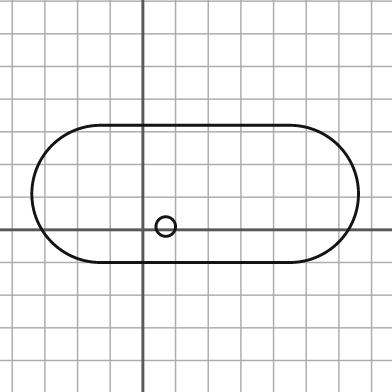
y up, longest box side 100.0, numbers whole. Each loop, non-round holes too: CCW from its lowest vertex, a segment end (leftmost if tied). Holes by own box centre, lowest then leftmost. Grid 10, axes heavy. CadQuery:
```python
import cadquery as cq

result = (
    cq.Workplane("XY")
    .moveTo(-13.0, -10.0)
    .lineTo(45.0, -10.0)
    .threePointArc((66.0, 11.0), (45.0, 32.0))
    .lineTo(-13.0, 32.0)
    .threePointArc((-34.0, 11.0), (-13.0, -10.0))
    .close()
    .moveTo(7.0, 1.0)
    .circle(3.0)
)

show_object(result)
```